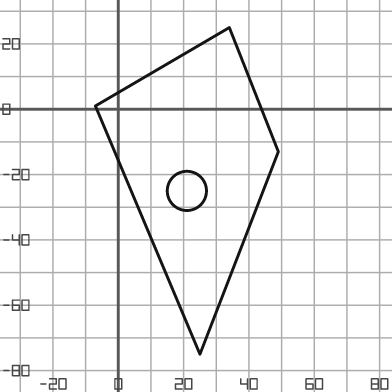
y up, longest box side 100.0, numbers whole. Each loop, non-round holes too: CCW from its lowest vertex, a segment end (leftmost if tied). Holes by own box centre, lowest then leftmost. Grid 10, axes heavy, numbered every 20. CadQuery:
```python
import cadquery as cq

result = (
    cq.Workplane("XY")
    .moveTo(25.0, -75.0)
    .lineTo(49.0, -13.0)
    .lineTo(34.0, 25.0)
    .lineTo(-7.0, 1.0)
    .close()
    .moveTo(21.0, -25.0)
    .circle(6.0)
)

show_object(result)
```